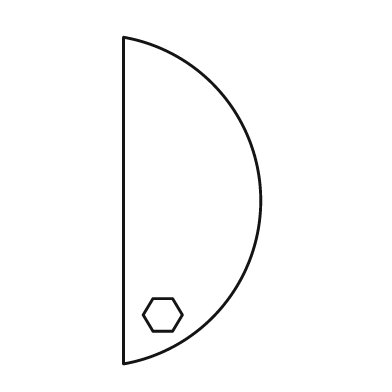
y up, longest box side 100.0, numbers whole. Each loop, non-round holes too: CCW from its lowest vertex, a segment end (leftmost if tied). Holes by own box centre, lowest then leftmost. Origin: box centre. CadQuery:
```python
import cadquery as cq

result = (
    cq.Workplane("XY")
    .moveTo(-21.0, -50.0)
    .threePointArc((21.0, 0.0), (-21.0, 50.0))
    .close()
    .moveTo(-12.0, -40.0)
    .lineTo(-6.0, -40.0)
    .lineTo(-3.0, -35.0)
    .lineTo(-6.0, -30.0)
    .lineTo(-12.0, -30.0)
    .lineTo(-15.0, -35.0)
    .close()
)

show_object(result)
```